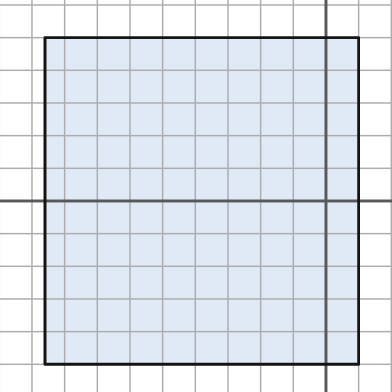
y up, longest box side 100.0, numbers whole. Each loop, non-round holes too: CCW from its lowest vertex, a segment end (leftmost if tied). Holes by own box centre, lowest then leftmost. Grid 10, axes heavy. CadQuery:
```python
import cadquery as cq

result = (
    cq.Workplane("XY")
    .moveTo(-86.0, -50.0)
    .lineTo(10.0, -50.0)
    .lineTo(10.0, 50.0)
    .lineTo(-86.0, 50.0)
    .close()
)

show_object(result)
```